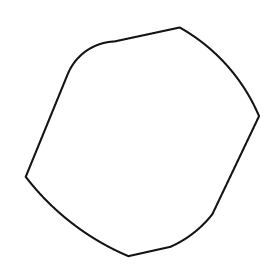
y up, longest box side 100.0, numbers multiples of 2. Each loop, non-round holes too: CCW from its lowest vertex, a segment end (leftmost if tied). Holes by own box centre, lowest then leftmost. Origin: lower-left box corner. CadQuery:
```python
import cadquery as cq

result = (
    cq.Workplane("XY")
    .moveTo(44.0, 0.0)
    .lineTo(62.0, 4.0)
    .threePointArc((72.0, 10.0), (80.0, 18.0))
    .lineTo(100.0, 60.0)
    .threePointArc((86.0, 82.0), (66.0, 98.0))
    .lineTo(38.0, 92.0)
    .threePointArc((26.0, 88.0), (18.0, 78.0))
    .lineTo(0.0, 34.0)
    .threePointArc((20.0, 14.0), (44.0, 0.0))
    .close()
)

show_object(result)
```